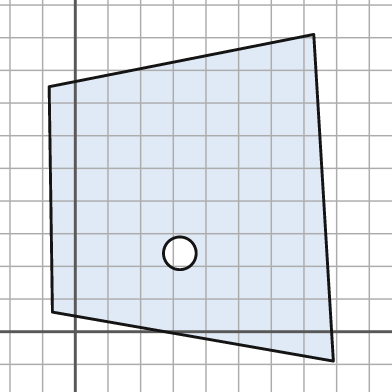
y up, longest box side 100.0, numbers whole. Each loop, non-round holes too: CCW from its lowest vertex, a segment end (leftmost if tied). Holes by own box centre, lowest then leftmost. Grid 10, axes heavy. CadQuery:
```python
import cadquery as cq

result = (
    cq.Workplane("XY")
    .moveTo(79.0, -9.0)
    .lineTo(73.0, 91.0)
    .lineTo(-8.0, 75.0)
    .lineTo(-7.0, 6.0)
    .close()
    .moveTo(32.0, 24.0)
    .circle(5.0)
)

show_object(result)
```